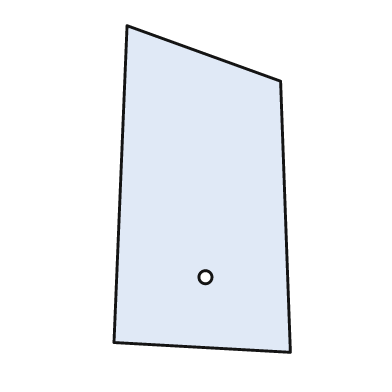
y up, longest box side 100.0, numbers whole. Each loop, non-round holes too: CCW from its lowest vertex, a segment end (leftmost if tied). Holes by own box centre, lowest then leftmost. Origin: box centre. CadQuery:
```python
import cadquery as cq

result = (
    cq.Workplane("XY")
    .moveTo(27.0, -50.0)
    .lineTo(24.0, 33.0)
    .lineTo(-23.0, 50.0)
    .lineTo(-27.0, -47.0)
    .close()
    .moveTo(1.0, -27.0)
    .circle(2.0)
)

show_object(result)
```